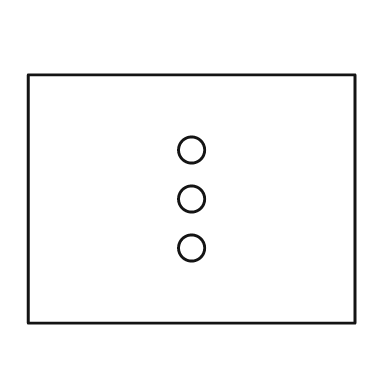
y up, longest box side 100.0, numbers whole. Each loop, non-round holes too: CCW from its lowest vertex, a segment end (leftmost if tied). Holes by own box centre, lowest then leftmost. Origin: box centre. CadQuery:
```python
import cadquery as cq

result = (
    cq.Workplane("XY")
    .moveTo(-50.0, -38.0)
    .lineTo(50.0, -38.0)
    .lineTo(50.0, 38.0)
    .lineTo(-50.0, 38.0)
    .close()
    .moveTo(0.0, -15.0)
    .circle(4.0)
    .moveTo(0.0, 0.0)
    .circle(4.0)
    .moveTo(0.0, 15.0)
    .circle(4.0)
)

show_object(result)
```